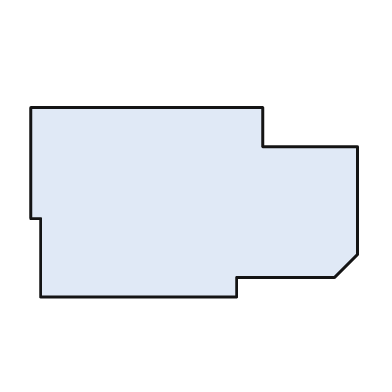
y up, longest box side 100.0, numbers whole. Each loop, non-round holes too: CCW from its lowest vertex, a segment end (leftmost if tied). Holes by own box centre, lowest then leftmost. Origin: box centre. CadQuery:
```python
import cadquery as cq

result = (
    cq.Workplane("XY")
    .moveTo(-47.0, -29.0)
    .lineTo(13.0, -29.0)
    .lineTo(13.0, -23.0)
    .lineTo(43.0, -23.0)
    .lineTo(50.0, -16.0)
    .lineTo(50.0, 17.0)
    .lineTo(21.0, 17.0)
    .lineTo(21.0, 29.0)
    .lineTo(-50.0, 29.0)
    .lineTo(-50.0, -5.0)
    .lineTo(-47.0, -5.0)
    .close()
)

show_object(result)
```